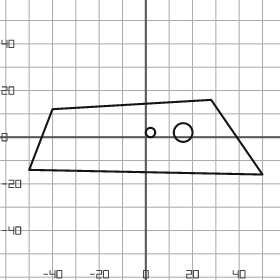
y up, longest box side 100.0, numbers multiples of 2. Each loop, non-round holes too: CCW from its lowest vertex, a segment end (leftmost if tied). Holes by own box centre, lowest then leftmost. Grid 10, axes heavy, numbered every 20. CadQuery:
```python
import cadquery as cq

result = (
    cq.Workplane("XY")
    .moveTo(50.0, -16.0)
    .lineTo(28.0, 16.0)
    .lineTo(-40.0, 12.0)
    .lineTo(-50.0, -14.0)
    .close()
    .moveTo(2.0, 2.0)
    .circle(2.0)
    .moveTo(16.0, 2.0)
    .circle(4.0)
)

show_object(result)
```